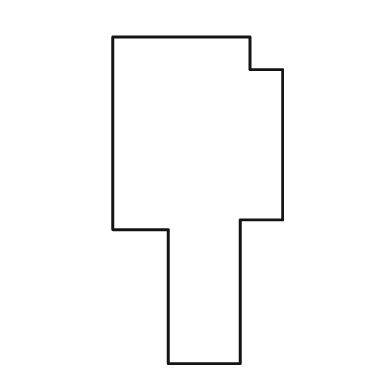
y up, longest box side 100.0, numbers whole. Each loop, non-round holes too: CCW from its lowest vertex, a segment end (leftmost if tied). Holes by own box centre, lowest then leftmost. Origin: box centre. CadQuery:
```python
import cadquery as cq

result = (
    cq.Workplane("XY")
    .moveTo(-9.0, -50.0)
    .lineTo(13.0, -50.0)
    .lineTo(13.0, -6.0)
    .lineTo(26.0, -6.0)
    .lineTo(26.0, 40.0)
    .lineTo(16.0, 40.0)
    .lineTo(16.0, 50.0)
    .lineTo(-26.0, 50.0)
    .lineTo(-26.0, -9.0)
    .lineTo(-9.0, -9.0)
    .close()
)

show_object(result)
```